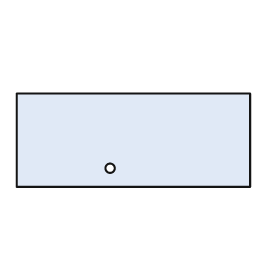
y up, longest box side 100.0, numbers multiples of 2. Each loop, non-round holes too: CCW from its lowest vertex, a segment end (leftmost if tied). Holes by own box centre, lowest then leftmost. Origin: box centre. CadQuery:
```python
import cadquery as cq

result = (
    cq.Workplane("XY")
    .moveTo(-50.0, -20.0)
    .lineTo(50.0, -20.0)
    .lineTo(50.0, 20.0)
    .lineTo(-50.0, 20.0)
    .close()
    .moveTo(-10.0, -12.0)
    .circle(2.0)
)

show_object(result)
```